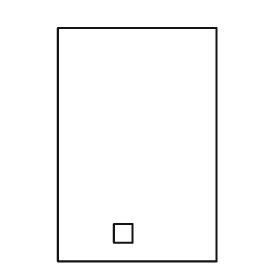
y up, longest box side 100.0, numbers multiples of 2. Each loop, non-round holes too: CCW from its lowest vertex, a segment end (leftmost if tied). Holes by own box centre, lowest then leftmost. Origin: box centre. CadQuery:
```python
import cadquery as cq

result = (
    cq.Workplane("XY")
    .moveTo(-34.0, -50.0)
    .lineTo(34.0, -50.0)
    .lineTo(34.0, 50.0)
    .lineTo(-34.0, 50.0)
    .close()
    .moveTo(-10.0, -42.0)
    .lineTo(-2.0, -42.0)
    .lineTo(-2.0, -34.0)
    .lineTo(-10.0, -34.0)
    .close()
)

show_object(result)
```